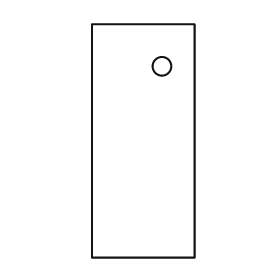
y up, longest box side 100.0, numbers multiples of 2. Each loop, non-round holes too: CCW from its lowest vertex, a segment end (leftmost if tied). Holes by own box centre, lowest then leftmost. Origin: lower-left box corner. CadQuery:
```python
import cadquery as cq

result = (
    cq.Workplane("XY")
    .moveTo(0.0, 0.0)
    .lineTo(44.0, 0.0)
    .lineTo(44.0, 100.0)
    .lineTo(0.0, 100.0)
    .close()
    .moveTo(30.0, 82.0)
    .circle(4.0)
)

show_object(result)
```